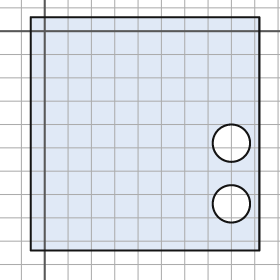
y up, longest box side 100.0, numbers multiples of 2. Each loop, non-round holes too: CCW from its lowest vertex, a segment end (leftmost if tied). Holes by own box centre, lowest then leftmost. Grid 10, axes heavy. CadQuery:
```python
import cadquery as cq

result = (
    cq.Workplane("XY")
    .moveTo(-6.0, -94.0)
    .lineTo(92.0, -94.0)
    .lineTo(92.0, 6.0)
    .lineTo(-6.0, 6.0)
    .close()
    .moveTo(80.0, -74.0)
    .circle(8.0)
    .moveTo(80.0, -48.0)
    .circle(8.0)
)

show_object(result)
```